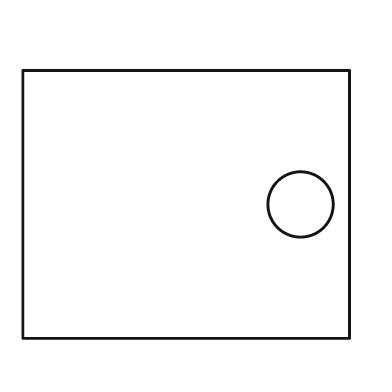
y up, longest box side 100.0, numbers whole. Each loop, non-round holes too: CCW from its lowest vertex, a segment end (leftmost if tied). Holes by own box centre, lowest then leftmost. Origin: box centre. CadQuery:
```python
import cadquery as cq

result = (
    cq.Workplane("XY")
    .moveTo(-50.0, -41.0)
    .lineTo(50.0, -41.0)
    .lineTo(50.0, 41.0)
    .lineTo(-50.0, 41.0)
    .close()
    .moveTo(35.0, 0.0)
    .circle(10.0)
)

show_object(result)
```